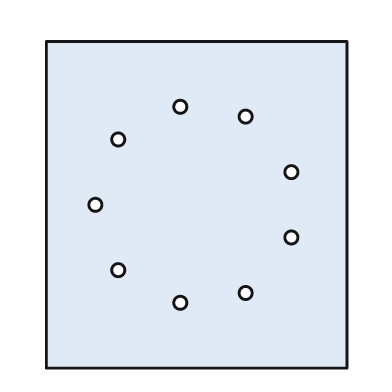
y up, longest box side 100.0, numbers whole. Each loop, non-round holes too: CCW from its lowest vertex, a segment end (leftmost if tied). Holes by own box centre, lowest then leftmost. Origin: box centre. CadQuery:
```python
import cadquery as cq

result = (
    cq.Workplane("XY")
    .moveTo(-46.0, -50.0)
    .lineTo(46.0, -50.0)
    .lineTo(46.0, 50.0)
    .lineTo(-46.0, 50.0)
    .close()
    .moveTo(-5.0, -30.0)
    .circle(2.0)
    .moveTo(15.0, -27.0)
    .circle(2.0)
    .moveTo(-24.0, -20.0)
    .circle(2.0)
    .moveTo(29.0, -10.0)
    .circle(2.0)
    .moveTo(-31.0, 0.0)
    .circle(2.0)
    .moveTo(29.0, 10.0)
    .circle(2.0)
    .moveTo(-24.0, 20.0)
    .circle(2.0)
    .moveTo(15.0, 27.0)
    .circle(2.0)
    .moveTo(-5.0, 30.0)
    .circle(2.0)
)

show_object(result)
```